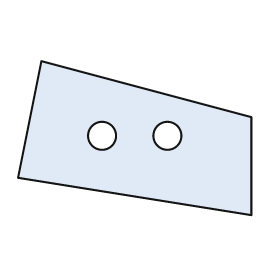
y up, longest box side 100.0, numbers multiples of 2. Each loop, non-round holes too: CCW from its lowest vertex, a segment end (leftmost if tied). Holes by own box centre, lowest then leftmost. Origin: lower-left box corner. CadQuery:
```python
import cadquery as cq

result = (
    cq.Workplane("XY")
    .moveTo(100.0, 0.0)
    .lineTo(100.0, 42.0)
    .lineTo(10.0, 66.0)
    .lineTo(0.0, 16.0)
    .close()
    .moveTo(36.0, 34.0)
    .circle(6.0)
    .moveTo(64.0, 34.0)
    .circle(6.0)
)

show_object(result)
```